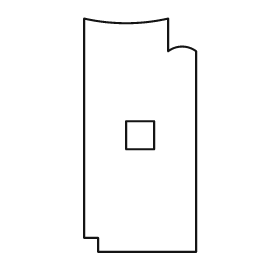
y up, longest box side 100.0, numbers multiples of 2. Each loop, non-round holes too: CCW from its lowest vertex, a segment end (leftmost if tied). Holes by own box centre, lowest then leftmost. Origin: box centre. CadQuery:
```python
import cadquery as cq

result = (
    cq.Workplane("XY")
    .moveTo(-18.0, -50.0)
    .lineTo(24.0, -50.0)
    .lineTo(24.0, 36.0)
    .threePointArc((18.0, 38.0), (12.0, 36.0))
    .lineTo(12.0, 50.0)
    .threePointArc((-6.0, 48.0), (-24.0, 50.0))
    .lineTo(-24.0, -44.0)
    .lineTo(-18.0, -44.0)
    .close()
    .moveTo(-6.0, -6.0)
    .lineTo(6.0, -6.0)
    .lineTo(6.0, 6.0)
    .lineTo(-6.0, 6.0)
    .close()
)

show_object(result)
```